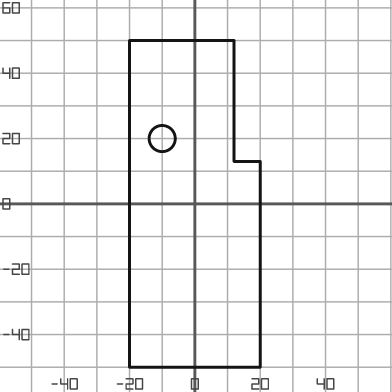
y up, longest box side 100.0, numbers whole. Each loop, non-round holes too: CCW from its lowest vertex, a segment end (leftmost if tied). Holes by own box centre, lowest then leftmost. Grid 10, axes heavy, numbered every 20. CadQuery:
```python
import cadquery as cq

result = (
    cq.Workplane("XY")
    .moveTo(-20.0, -50.0)
    .lineTo(20.0, -50.0)
    .lineTo(20.0, 13.0)
    .lineTo(12.0, 13.0)
    .lineTo(12.0, 50.0)
    .lineTo(-20.0, 50.0)
    .close()
    .moveTo(-10.0, 20.0)
    .circle(4.0)
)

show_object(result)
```